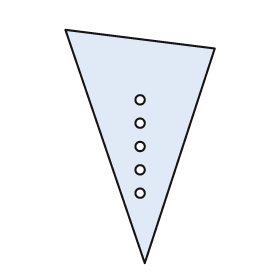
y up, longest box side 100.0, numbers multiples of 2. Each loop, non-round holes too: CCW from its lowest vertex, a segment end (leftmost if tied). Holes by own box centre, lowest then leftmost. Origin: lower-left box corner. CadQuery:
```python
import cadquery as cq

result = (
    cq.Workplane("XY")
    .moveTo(34.0, 0.0)
    .lineTo(64.0, 92.0)
    .lineTo(0.0, 100.0)
    .close()
    .moveTo(32.0, 30.0)
    .circle(2.0)
    .moveTo(32.0, 40.0)
    .circle(2.0)
    .moveTo(32.0, 50.0)
    .circle(2.0)
    .moveTo(32.0, 60.0)
    .circle(2.0)
    .moveTo(32.0, 70.0)
    .circle(2.0)
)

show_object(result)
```